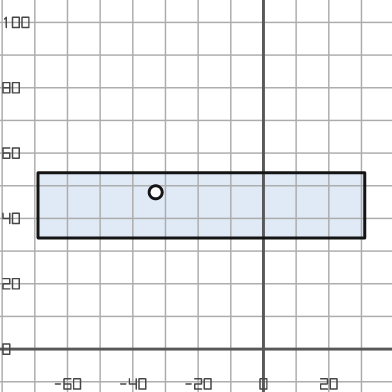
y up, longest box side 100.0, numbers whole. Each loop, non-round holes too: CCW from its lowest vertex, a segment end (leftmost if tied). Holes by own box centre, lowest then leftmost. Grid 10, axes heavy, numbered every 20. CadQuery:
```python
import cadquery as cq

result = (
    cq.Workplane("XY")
    .moveTo(-69.0, 34.0)
    .lineTo(31.0, 34.0)
    .lineTo(31.0, 54.0)
    .lineTo(-69.0, 54.0)
    .close()
    .moveTo(-33.0, 48.0)
    .circle(2.0)
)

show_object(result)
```